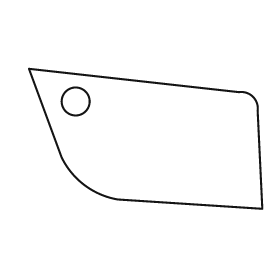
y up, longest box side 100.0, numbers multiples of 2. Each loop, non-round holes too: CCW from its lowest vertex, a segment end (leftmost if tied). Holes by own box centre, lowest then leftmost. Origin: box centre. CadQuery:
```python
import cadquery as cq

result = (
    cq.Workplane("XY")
    .moveTo(50.0, -30.0)
    .lineTo(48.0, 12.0)
    .threePointArc((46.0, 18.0), (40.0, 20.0))
    .lineTo(-50.0, 30.0)
    .lineTo(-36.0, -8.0)
    .threePointArc((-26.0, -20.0), (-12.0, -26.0))
    .close()
    .moveTo(-30.0, 16.0)
    .circle(6.0)
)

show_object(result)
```